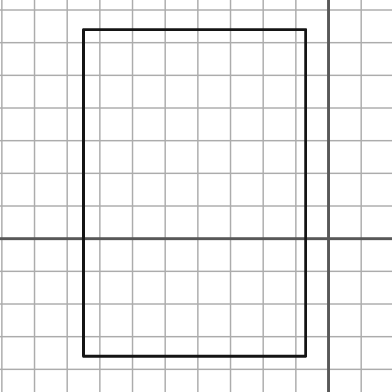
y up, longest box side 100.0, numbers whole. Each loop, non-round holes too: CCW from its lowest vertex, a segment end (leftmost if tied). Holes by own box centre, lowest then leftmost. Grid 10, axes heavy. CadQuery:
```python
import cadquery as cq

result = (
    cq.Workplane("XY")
    .moveTo(-75.0, -36.0)
    .lineTo(-7.0, -36.0)
    .lineTo(-7.0, 64.0)
    .lineTo(-75.0, 64.0)
    .close()
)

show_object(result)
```